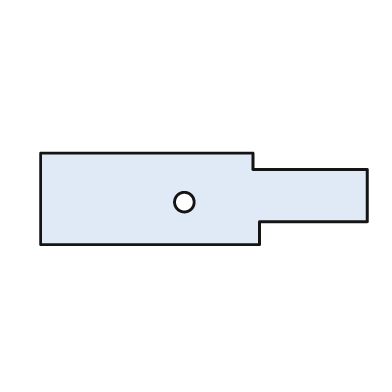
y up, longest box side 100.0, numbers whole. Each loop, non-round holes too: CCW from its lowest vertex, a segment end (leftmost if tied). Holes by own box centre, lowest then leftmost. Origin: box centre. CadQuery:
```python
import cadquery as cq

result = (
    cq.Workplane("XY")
    .moveTo(-50.0, -14.0)
    .lineTo(17.0, -14.0)
    .lineTo(17.0, -7.0)
    .lineTo(50.0, -7.0)
    .lineTo(50.0, 9.0)
    .lineTo(15.0, 9.0)
    .lineTo(15.0, 14.0)
    .lineTo(-50.0, 14.0)
    .close()
    .moveTo(-6.0, -1.0)
    .circle(3.0)
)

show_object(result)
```